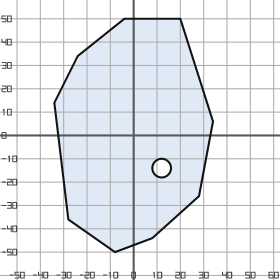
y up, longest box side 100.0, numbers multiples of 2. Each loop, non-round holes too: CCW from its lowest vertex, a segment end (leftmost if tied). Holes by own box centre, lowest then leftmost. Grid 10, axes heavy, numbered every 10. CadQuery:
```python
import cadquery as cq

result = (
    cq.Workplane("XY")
    .moveTo(-8.0, -50.0)
    .lineTo(8.0, -44.0)
    .lineTo(28.0, -26.0)
    .lineTo(34.0, 6.0)
    .lineTo(20.0, 50.0)
    .lineTo(-4.0, 50.0)
    .lineTo(-24.0, 34.0)
    .lineTo(-34.0, 14.0)
    .lineTo(-28.0, -36.0)
    .close()
    .moveTo(12.0, -14.0)
    .circle(4.0)
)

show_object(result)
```